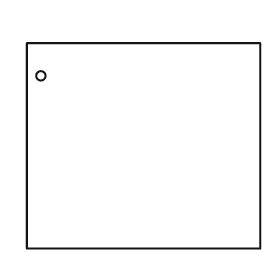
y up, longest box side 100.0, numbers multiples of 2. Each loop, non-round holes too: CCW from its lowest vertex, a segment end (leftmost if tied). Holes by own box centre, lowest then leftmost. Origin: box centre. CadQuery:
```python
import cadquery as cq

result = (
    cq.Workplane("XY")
    .moveTo(-50.0, -44.0)
    .lineTo(50.0, -44.0)
    .lineTo(50.0, 44.0)
    .lineTo(-50.0, 44.0)
    .close()
    .moveTo(-44.0, 30.0)
    .circle(2.0)
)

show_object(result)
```